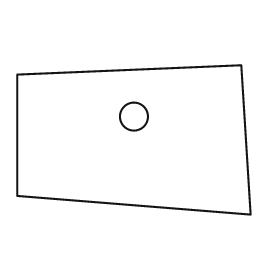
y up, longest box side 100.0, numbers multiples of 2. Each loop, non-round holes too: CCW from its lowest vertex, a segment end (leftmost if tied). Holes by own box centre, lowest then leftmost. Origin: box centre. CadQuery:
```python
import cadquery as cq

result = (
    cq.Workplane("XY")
    .moveTo(50.0, -32.0)
    .lineTo(46.0, 32.0)
    .lineTo(-50.0, 28.0)
    .lineTo(-50.0, -24.0)
    .close()
    .moveTo(0.0, 10.0)
    .circle(6.0)
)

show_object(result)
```